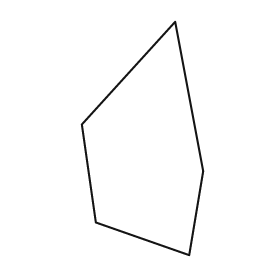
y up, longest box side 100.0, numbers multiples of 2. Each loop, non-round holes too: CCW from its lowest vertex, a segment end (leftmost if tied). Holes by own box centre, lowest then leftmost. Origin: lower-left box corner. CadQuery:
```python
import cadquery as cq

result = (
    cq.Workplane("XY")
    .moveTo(46.0, 0.0)
    .lineTo(52.0, 36.0)
    .lineTo(40.0, 100.0)
    .lineTo(0.0, 56.0)
    .lineTo(6.0, 14.0)
    .close()
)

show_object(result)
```